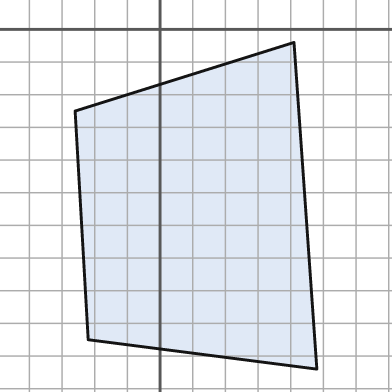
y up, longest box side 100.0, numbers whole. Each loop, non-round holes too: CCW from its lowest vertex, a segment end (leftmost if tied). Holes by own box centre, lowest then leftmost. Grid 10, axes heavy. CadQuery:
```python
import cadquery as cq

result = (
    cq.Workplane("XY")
    .moveTo(48.0, -104.0)
    .lineTo(41.0, -4.0)
    .lineTo(-26.0, -25.0)
    .lineTo(-22.0, -95.0)
    .close()
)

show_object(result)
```